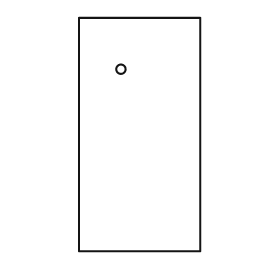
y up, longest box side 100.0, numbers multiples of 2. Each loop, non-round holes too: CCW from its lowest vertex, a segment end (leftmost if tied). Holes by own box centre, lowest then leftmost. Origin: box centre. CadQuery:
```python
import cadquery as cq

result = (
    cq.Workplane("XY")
    .moveTo(-26.0, -50.0)
    .lineTo(26.0, -50.0)
    .lineTo(26.0, 50.0)
    .lineTo(-26.0, 50.0)
    .close()
    .moveTo(-8.0, 28.0)
    .circle(2.0)
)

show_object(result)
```